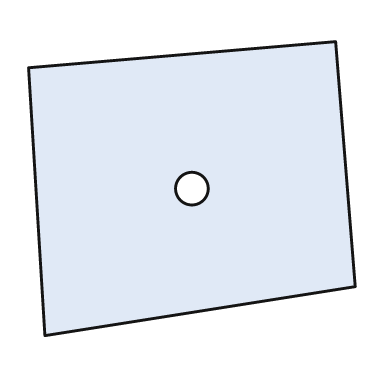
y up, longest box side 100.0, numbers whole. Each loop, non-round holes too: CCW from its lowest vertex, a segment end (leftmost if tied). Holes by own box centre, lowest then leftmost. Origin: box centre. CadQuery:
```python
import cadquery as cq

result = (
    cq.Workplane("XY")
    .moveTo(-45.0, -45.0)
    .lineTo(50.0, -30.0)
    .lineTo(44.0, 45.0)
    .lineTo(-50.0, 37.0)
    .close()
    .moveTo(0.0, 0.0)
    .circle(5.0)
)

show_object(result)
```